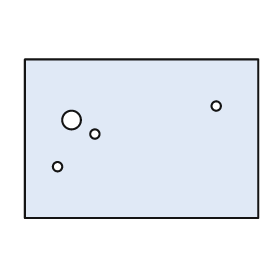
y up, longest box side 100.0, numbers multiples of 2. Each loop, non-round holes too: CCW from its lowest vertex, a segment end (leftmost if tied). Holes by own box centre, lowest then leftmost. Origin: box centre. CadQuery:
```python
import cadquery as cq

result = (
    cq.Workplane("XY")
    .moveTo(-50.0, -34.0)
    .lineTo(50.0, -34.0)
    .lineTo(50.0, 34.0)
    .lineTo(-50.0, 34.0)
    .close()
    .moveTo(-36.0, -12.0)
    .circle(2.0)
    .moveTo(-20.0, 2.0)
    .circle(2.0)
    .moveTo(-30.0, 8.0)
    .circle(4.0)
    .moveTo(32.0, 14.0)
    .circle(2.0)
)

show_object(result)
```